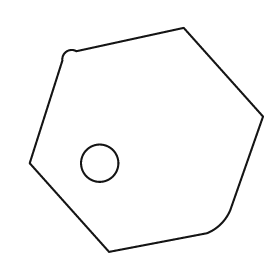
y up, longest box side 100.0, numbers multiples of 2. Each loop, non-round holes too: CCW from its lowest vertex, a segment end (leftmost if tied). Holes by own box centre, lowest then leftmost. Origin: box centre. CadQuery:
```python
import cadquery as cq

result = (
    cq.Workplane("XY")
    .moveTo(-16.0, -48.0)
    .lineTo(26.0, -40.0)
    .threePointArc((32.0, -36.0), (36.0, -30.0))
    .lineTo(50.0, 10.0)
    .lineTo(16.0, 48.0)
    .lineTo(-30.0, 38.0)
    .threePointArc((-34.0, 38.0), (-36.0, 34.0))
    .lineTo(-50.0, -10.0)
    .close()
    .moveTo(-20.0, -10.0)
    .circle(8.0)
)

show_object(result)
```